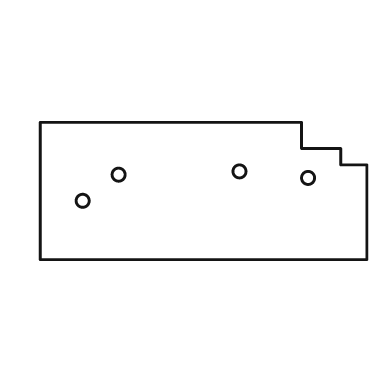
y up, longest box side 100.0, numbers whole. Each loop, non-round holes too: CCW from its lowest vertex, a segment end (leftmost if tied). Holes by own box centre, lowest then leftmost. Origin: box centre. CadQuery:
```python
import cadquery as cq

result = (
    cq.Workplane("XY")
    .moveTo(-50.0, -21.0)
    .lineTo(50.0, -21.0)
    .lineTo(50.0, 8.0)
    .lineTo(42.0, 8.0)
    .lineTo(42.0, 13.0)
    .lineTo(30.0, 13.0)
    .lineTo(30.0, 21.0)
    .lineTo(-50.0, 21.0)
    .close()
    .moveTo(-37.0, -3.0)
    .circle(2.0)
    .moveTo(32.0, 4.0)
    .circle(2.0)
    .moveTo(-26.0, 5.0)
    .circle(2.0)
    .moveTo(11.0, 6.0)
    .circle(2.0)
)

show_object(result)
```